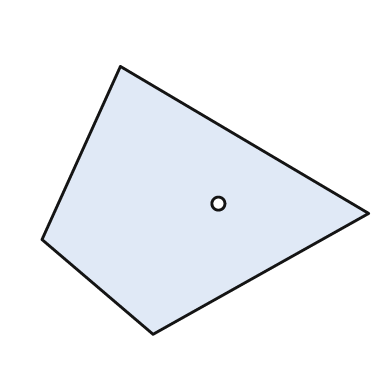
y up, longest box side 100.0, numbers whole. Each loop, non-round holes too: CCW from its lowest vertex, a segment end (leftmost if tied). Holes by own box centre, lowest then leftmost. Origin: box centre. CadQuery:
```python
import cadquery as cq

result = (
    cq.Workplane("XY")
    .moveTo(-16.0, -41.0)
    .lineTo(50.0, -4.0)
    .lineTo(-26.0, 41.0)
    .lineTo(-50.0, -12.0)
    .close()
    .moveTo(4.0, -1.0)
    .circle(2.0)
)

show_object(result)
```